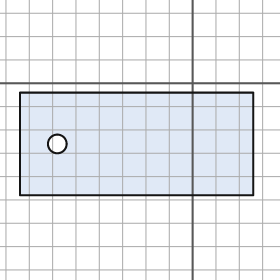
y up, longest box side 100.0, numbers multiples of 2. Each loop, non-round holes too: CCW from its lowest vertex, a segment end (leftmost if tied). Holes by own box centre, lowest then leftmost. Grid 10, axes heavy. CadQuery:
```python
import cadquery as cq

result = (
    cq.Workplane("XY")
    .moveTo(-74.0, -48.0)
    .lineTo(26.0, -48.0)
    .lineTo(26.0, -4.0)
    .lineTo(-74.0, -4.0)
    .close()
    .moveTo(-58.0, -26.0)
    .circle(4.0)
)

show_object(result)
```